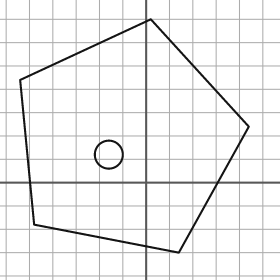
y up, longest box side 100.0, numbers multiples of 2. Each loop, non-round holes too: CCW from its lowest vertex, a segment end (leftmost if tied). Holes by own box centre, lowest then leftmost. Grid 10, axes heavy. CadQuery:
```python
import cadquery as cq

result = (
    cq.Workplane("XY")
    .moveTo(14.0, -30.0)
    .lineTo(44.0, 24.0)
    .lineTo(2.0, 70.0)
    .lineTo(-54.0, 44.0)
    .lineTo(-48.0, -18.0)
    .close()
    .moveTo(-16.0, 12.0)
    .circle(6.0)
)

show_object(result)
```